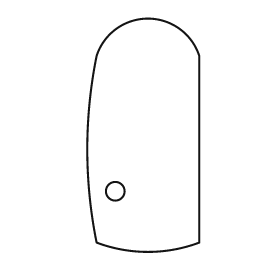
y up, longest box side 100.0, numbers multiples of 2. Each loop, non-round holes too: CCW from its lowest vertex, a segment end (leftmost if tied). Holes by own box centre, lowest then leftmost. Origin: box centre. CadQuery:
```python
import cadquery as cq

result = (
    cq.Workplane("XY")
    .moveTo(-20.0, -46.0)
    .threePointArc((2.0, -50.0), (24.0, -46.0))
    .lineTo(24.0, 34.0)
    .threePointArc((2.0, 50.0), (-20.0, 34.0))
    .threePointArc((-24.0, -6.0), (-20.0, -46.0))
    .close()
    .moveTo(-12.0, -24.0)
    .circle(4.0)
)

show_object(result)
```